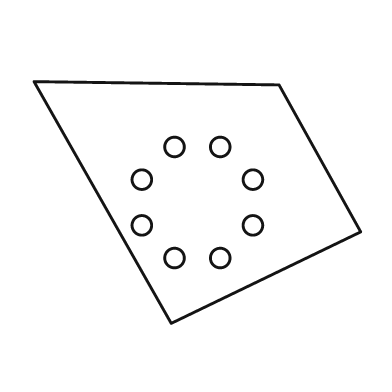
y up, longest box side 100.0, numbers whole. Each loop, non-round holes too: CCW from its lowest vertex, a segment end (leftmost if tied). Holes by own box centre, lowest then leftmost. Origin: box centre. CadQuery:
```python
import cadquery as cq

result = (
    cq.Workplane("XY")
    .moveTo(-8.0, -37.0)
    .lineTo(50.0, -9.0)
    .lineTo(25.0, 36.0)
    .lineTo(-50.0, 37.0)
    .close()
    .moveTo(-7.0, -17.0)
    .circle(3.0)
    .moveTo(7.0, -17.0)
    .circle(3.0)
    .moveTo(-17.0, -7.0)
    .circle(3.0)
    .moveTo(17.0, -7.0)
    .circle(3.0)
    .moveTo(-17.0, 7.0)
    .circle(3.0)
    .moveTo(17.0, 7.0)
    .circle(3.0)
    .moveTo(-7.0, 17.0)
    .circle(3.0)
    .moveTo(7.0, 17.0)
    .circle(3.0)
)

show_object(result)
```